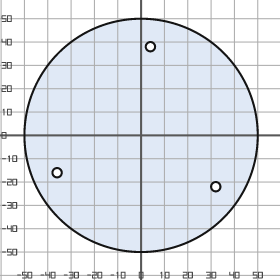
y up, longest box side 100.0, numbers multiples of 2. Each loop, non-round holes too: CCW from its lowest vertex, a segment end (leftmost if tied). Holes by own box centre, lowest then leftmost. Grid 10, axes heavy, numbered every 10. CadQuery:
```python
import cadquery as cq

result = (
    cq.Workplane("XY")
    .moveTo(0.0, 0.0)
    .circle(50.0)
    .moveTo(32.0, -22.0)
    .circle(2.0)
    .moveTo(-36.0, -16.0)
    .circle(2.0)
    .moveTo(4.0, 38.0)
    .circle(2.0)
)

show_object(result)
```